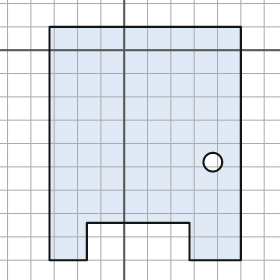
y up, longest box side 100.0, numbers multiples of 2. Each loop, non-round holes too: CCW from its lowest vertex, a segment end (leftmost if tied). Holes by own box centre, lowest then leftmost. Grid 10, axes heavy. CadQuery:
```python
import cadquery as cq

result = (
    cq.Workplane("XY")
    .moveTo(-32.0, -90.0)
    .lineTo(-16.0, -90.0)
    .lineTo(-16.0, -74.0)
    .lineTo(28.0, -74.0)
    .lineTo(28.0, -90.0)
    .lineTo(50.0, -90.0)
    .lineTo(50.0, 10.0)
    .lineTo(-32.0, 10.0)
    .close()
    .moveTo(38.0, -48.0)
    .circle(4.0)
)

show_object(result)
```